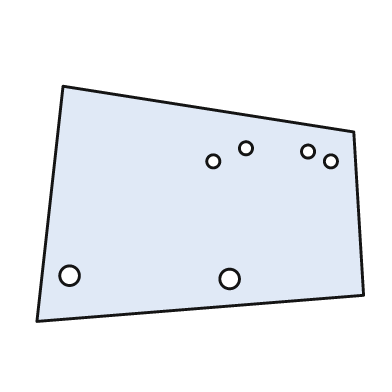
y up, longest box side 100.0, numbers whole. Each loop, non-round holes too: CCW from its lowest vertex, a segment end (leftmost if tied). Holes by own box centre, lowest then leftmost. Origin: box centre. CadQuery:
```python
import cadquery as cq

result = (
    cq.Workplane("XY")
    .moveTo(-50.0, -36.0)
    .lineTo(50.0, -28.0)
    .lineTo(47.0, 22.0)
    .lineTo(-42.0, 36.0)
    .close()
    .moveTo(9.0, -23.0)
    .circle(3.0)
    .moveTo(-40.0, -22.0)
    .circle(3.0)
    .moveTo(4.0, 13.0)
    .circle(2.0)
    .moveTo(40.0, 13.0)
    .circle(2.0)
    .moveTo(33.0, 16.0)
    .circle(2.0)
    .moveTo(14.0, 17.0)
    .circle(2.0)
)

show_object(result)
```